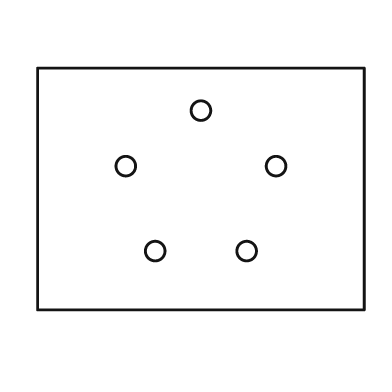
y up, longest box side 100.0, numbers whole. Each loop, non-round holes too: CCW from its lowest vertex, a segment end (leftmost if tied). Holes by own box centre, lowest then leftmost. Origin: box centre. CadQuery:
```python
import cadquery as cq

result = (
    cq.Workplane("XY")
    .moveTo(-50.0, -37.0)
    .lineTo(50.0, -37.0)
    .lineTo(50.0, 37.0)
    .lineTo(-50.0, 37.0)
    .close()
    .moveTo(-14.0, -19.0)
    .circle(3.0)
    .moveTo(14.0, -19.0)
    .circle(3.0)
    .moveTo(-23.0, 7.0)
    .circle(3.0)
    .moveTo(23.0, 7.0)
    .circle(3.0)
    .moveTo(0.0, 24.0)
    .circle(3.0)
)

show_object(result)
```